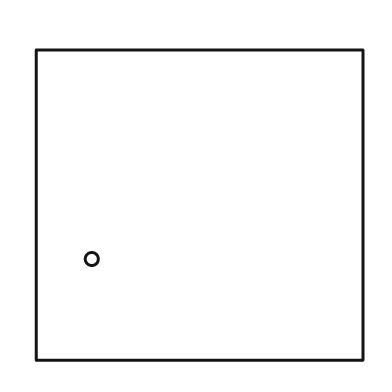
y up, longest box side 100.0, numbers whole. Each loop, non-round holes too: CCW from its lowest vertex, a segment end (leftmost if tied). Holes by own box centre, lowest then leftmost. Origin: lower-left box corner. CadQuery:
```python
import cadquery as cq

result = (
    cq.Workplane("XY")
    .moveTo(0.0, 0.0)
    .lineTo(100.0, 0.0)
    .lineTo(100.0, 95.0)
    .lineTo(0.0, 95.0)
    .close()
    .moveTo(17.0, 31.0)
    .circle(2.0)
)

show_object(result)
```